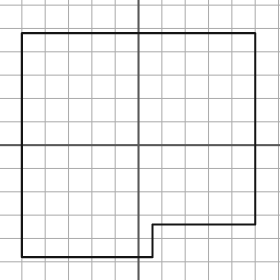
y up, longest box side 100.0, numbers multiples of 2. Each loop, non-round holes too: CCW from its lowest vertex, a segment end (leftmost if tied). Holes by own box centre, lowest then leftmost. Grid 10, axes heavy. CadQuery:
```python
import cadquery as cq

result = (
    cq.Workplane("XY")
    .moveTo(-50.0, -48.0)
    .lineTo(6.0, -48.0)
    .lineTo(6.0, -34.0)
    .lineTo(50.0, -34.0)
    .lineTo(50.0, 48.0)
    .lineTo(-50.0, 48.0)
    .close()
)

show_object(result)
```